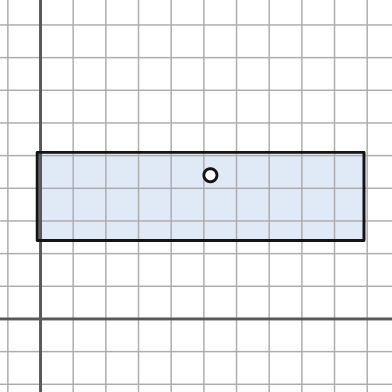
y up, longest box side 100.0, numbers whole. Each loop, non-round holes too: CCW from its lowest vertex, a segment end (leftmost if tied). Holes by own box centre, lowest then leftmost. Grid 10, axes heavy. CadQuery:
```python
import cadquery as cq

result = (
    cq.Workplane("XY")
    .moveTo(-1.0, 24.0)
    .lineTo(99.0, 24.0)
    .lineTo(99.0, 51.0)
    .lineTo(-1.0, 51.0)
    .close()
    .moveTo(52.0, 44.0)
    .circle(2.0)
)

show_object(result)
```